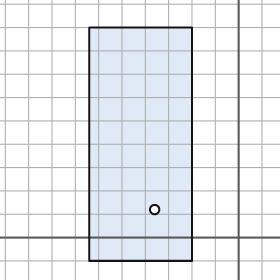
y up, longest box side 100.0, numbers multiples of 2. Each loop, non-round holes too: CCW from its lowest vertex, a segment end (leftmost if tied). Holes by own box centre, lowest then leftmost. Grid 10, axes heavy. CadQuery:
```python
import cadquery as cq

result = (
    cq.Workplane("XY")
    .moveTo(-64.0, -10.0)
    .lineTo(-20.0, -10.0)
    .lineTo(-20.0, 90.0)
    .lineTo(-64.0, 90.0)
    .close()
    .moveTo(-36.0, 12.0)
    .circle(2.0)
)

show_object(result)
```